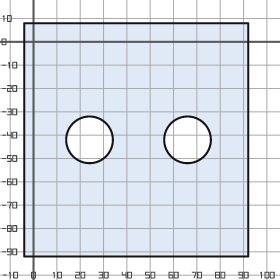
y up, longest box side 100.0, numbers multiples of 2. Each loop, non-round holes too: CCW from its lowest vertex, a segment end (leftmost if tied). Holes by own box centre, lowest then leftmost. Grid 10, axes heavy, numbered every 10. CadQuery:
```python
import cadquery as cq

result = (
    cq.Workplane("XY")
    .moveTo(-4.0, -92.0)
    .lineTo(92.0, -92.0)
    .lineTo(92.0, 8.0)
    .lineTo(-4.0, 8.0)
    .close()
    .moveTo(24.0, -42.0)
    .circle(10.0)
    .moveTo(66.0, -42.0)
    .circle(10.0)
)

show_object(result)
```